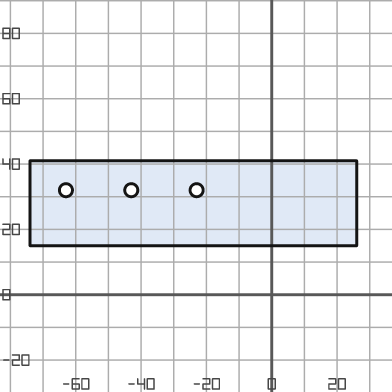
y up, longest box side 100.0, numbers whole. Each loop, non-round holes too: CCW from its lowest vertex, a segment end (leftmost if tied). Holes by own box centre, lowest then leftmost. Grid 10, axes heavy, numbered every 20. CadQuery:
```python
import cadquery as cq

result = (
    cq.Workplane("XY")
    .moveTo(-74.0, 15.0)
    .lineTo(26.0, 15.0)
    .lineTo(26.0, 41.0)
    .lineTo(-74.0, 41.0)
    .close()
    .moveTo(-63.0, 32.0)
    .circle(2.0)
    .moveTo(-43.0, 32.0)
    .circle(2.0)
    .moveTo(-23.0, 32.0)
    .circle(2.0)
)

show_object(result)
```